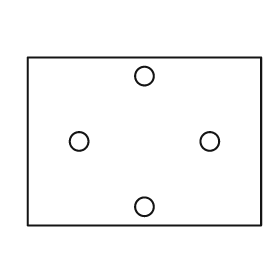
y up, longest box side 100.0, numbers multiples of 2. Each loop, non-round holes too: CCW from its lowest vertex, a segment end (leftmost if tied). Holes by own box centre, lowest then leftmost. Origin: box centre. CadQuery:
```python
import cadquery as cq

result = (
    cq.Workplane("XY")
    .moveTo(-50.0, -36.0)
    .lineTo(50.0, -36.0)
    .lineTo(50.0, 36.0)
    .lineTo(-50.0, 36.0)
    .close()
    .moveTo(0.0, -28.0)
    .circle(4.0)
    .moveTo(-28.0, 0.0)
    .circle(4.0)
    .moveTo(28.0, 0.0)
    .circle(4.0)
    .moveTo(0.0, 28.0)
    .circle(4.0)
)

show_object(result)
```